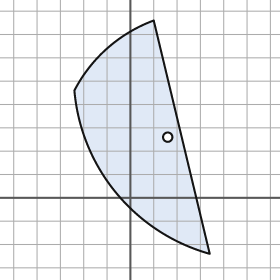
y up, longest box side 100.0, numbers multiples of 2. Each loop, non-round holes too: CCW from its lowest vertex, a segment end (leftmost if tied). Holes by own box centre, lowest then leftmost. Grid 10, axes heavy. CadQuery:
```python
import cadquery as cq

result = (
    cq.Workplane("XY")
    .moveTo(34.0, -24.0)
    .lineTo(10.0, 76.0)
    .threePointArc((-10.0, 64.0), (-24.0, 46.0))
    .threePointArc((-6.0, 2.0), (34.0, -24.0))
    .close()
    .moveTo(16.0, 26.0)
    .circle(2.0)
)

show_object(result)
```